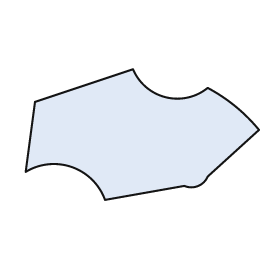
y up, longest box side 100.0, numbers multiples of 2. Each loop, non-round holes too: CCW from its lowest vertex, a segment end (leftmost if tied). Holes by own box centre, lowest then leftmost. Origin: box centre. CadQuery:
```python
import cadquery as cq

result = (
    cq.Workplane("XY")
    .moveTo(-16.0, -28.0)
    .lineTo(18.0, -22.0)
    .threePointArc((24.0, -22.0), (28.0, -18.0))
    .lineTo(50.0, 2.0)
    .threePointArc((40.0, 12.0), (28.0, 20.0))
    .threePointArc((10.0, 16.0), (-4.0, 28.0))
    .lineTo(-46.0, 14.0)
    .lineTo(-50.0, -16.0)
    .threePointArc((-30.0, -14.0), (-16.0, -28.0))
    .close()
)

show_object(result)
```